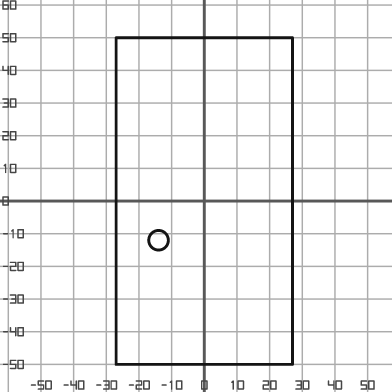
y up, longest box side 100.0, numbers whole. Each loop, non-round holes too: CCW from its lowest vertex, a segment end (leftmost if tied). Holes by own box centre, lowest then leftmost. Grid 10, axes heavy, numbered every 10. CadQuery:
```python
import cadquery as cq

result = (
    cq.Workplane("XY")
    .moveTo(-27.0, -50.0)
    .lineTo(27.0, -50.0)
    .lineTo(27.0, 50.0)
    .lineTo(-27.0, 50.0)
    .close()
    .moveTo(-14.0, -12.0)
    .circle(3.0)
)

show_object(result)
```